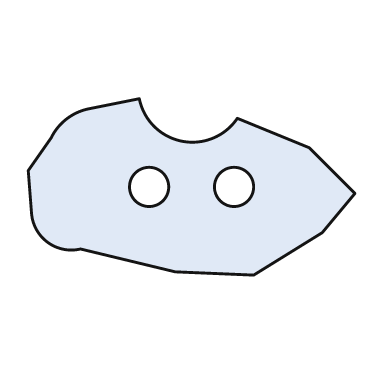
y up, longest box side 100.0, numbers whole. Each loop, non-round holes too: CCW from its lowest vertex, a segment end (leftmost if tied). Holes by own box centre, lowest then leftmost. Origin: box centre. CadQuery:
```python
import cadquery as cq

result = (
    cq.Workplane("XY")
    .moveTo(19.0, -27.0)
    .lineTo(40.0, -14.0)
    .lineTo(50.0, -2.0)
    .lineTo(36.0, 12.0)
    .lineTo(14.0, 21.0)
    .threePointArc((-3.0, 14.0), (-16.0, 27.0))
    .lineTo(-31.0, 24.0)
    .threePointArc((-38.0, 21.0), (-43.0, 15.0))
    .lineTo(-50.0, 5.0)
    .lineTo(-49.0, -8.0)
    .threePointArc((-44.0, -17.0), (-34.0, -19.0))
    .lineTo(-5.0, -26.0)
    .close()
    .moveTo(-13.0, 0.0)
    .circle(6.0)
    .moveTo(13.0, 0.0)
    .circle(6.0)
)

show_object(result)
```